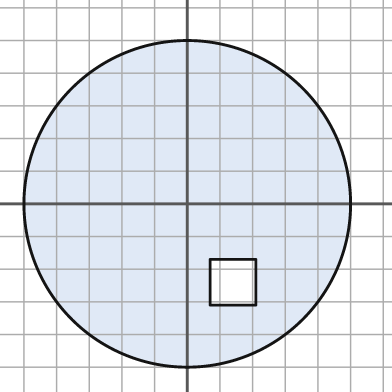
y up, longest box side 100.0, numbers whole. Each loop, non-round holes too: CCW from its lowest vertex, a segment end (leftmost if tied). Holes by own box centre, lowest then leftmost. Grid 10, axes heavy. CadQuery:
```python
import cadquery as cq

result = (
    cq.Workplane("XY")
    .moveTo(0.0, 0.0)
    .circle(50.0)
    .moveTo(7.0, -31.0)
    .lineTo(21.0, -31.0)
    .lineTo(21.0, -17.0)
    .lineTo(7.0, -17.0)
    .close()
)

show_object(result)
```